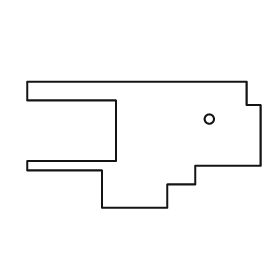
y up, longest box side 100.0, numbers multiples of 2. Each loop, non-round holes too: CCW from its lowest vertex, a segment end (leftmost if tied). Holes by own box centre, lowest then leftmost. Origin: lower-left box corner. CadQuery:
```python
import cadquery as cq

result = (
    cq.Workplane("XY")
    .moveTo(32.0, 0.0)
    .lineTo(60.0, 0.0)
    .lineTo(60.0, 10.0)
    .lineTo(72.0, 10.0)
    .lineTo(72.0, 18.0)
    .lineTo(100.0, 18.0)
    .lineTo(100.0, 44.0)
    .lineTo(94.0, 44.0)
    .lineTo(94.0, 54.0)
    .lineTo(0.0, 54.0)
    .lineTo(0.0, 46.0)
    .lineTo(38.0, 46.0)
    .lineTo(38.0, 20.0)
    .lineTo(0.0, 20.0)
    .lineTo(0.0, 16.0)
    .lineTo(32.0, 16.0)
    .close()
    .moveTo(78.0, 38.0)
    .circle(2.0)
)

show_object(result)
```